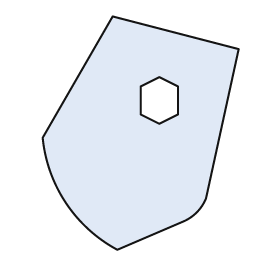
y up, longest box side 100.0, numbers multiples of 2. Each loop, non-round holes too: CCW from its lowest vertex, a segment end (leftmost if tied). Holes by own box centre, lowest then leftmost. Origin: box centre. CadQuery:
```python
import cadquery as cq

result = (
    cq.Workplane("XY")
    .moveTo(-10.0, -50.0)
    .lineTo(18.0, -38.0)
    .threePointArc((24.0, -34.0), (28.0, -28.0))
    .lineTo(42.0, 36.0)
    .lineTo(-12.0, 50.0)
    .lineTo(-42.0, -2.0)
    .threePointArc((-32.0, -30.0), (-10.0, -50.0))
    .close()
    .moveTo(8.0, 4.0)
    .lineTo(16.0, 8.0)
    .lineTo(16.0, 20.0)
    .lineTo(8.0, 24.0)
    .lineTo(0.0, 20.0)
    .lineTo(0.0, 8.0)
    .close()
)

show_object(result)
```